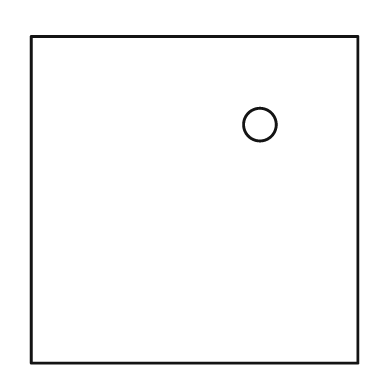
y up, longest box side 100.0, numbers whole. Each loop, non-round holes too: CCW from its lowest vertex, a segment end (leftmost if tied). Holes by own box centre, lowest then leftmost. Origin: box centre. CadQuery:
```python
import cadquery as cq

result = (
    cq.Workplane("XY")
    .moveTo(-50.0, -50.0)
    .lineTo(50.0, -50.0)
    .lineTo(50.0, 50.0)
    .lineTo(-50.0, 50.0)
    .close()
    .moveTo(20.0, 23.0)
    .circle(5.0)
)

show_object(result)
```